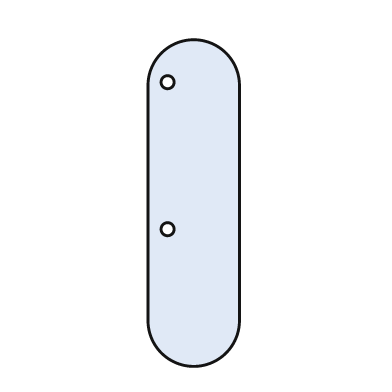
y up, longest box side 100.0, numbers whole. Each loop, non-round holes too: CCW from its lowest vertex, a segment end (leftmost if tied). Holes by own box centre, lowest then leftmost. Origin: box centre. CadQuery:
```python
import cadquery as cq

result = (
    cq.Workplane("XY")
    .moveTo(-14.0, -36.0)
    .threePointArc((0.0, -50.0), (14.0, -36.0))
    .lineTo(14.0, 36.0)
    .threePointArc((0.0, 50.0), (-14.0, 36.0))
    .close()
    .moveTo(-8.0, -8.0)
    .circle(2.0)
    .moveTo(-8.0, 37.0)
    .circle(2.0)
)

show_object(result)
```